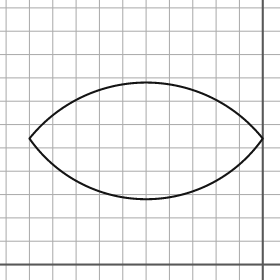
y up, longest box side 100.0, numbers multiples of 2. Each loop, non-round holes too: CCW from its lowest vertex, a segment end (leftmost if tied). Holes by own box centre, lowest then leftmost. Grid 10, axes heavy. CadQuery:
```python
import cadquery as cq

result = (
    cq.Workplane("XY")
    .moveTo(-100.0, 54.0)
    .threePointArc((-50.0, 28.0), (0.0, 54.0))
    .threePointArc((-50.0, 78.0), (-100.0, 54.0))
    .close()
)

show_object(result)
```